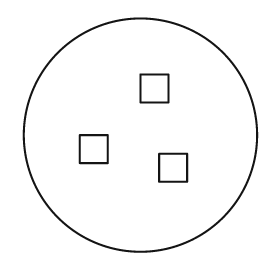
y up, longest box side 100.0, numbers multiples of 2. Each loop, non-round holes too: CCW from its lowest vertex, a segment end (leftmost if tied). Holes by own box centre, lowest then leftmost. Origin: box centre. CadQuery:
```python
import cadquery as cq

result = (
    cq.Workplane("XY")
    .moveTo(0.0, 0.0)
    .circle(50.0)
    .moveTo(8.0, -20.0)
    .lineTo(20.0, -20.0)
    .lineTo(20.0, -8.0)
    .lineTo(8.0, -8.0)
    .close()
    .moveTo(-26.0, -12.0)
    .lineTo(-14.0, -12.0)
    .lineTo(-14.0, 0.0)
    .lineTo(-26.0, 0.0)
    .close()
    .moveTo(0.0, 14.0)
    .lineTo(12.0, 14.0)
    .lineTo(12.0, 26.0)
    .lineTo(0.0, 26.0)
    .close()
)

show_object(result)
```